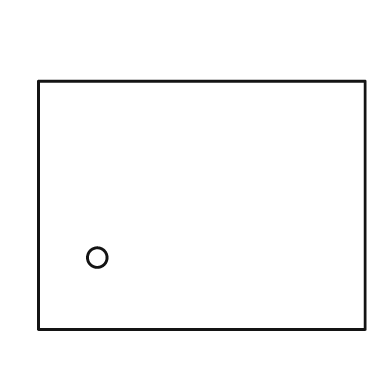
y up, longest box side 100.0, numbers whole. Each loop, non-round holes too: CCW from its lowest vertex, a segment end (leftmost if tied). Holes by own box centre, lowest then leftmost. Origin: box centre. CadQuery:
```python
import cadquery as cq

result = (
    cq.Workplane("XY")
    .moveTo(-50.0, -38.0)
    .lineTo(50.0, -38.0)
    .lineTo(50.0, 38.0)
    .lineTo(-50.0, 38.0)
    .close()
    .moveTo(-32.0, -16.0)
    .circle(3.0)
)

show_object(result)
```